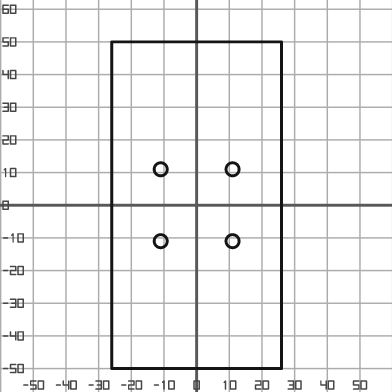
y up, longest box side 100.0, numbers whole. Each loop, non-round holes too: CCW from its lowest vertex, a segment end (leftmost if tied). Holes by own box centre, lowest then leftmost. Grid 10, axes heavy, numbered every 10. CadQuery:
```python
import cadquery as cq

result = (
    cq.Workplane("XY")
    .moveTo(-26.0, -50.0)
    .lineTo(26.0, -50.0)
    .lineTo(26.0, 50.0)
    .lineTo(-26.0, 50.0)
    .close()
    .moveTo(-11.0, -11.0)
    .circle(2.0)
    .moveTo(11.0, -11.0)
    .circle(2.0)
    .moveTo(-11.0, 11.0)
    .circle(2.0)
    .moveTo(11.0, 11.0)
    .circle(2.0)
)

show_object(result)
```